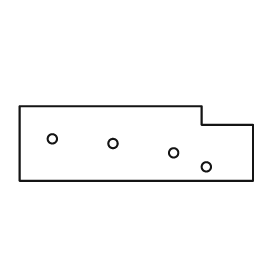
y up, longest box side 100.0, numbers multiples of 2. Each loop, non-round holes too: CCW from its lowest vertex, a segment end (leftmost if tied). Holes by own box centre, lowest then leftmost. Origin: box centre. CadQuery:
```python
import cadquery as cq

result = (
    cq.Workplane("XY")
    .moveTo(-50.0, -16.0)
    .lineTo(50.0, -16.0)
    .lineTo(50.0, 8.0)
    .lineTo(28.0, 8.0)
    .lineTo(28.0, 16.0)
    .lineTo(-50.0, 16.0)
    .close()
    .moveTo(30.0, -10.0)
    .circle(2.0)
    .moveTo(16.0, -4.0)
    .circle(2.0)
    .moveTo(-10.0, 0.0)
    .circle(2.0)
    .moveTo(-36.0, 2.0)
    .circle(2.0)
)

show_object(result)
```